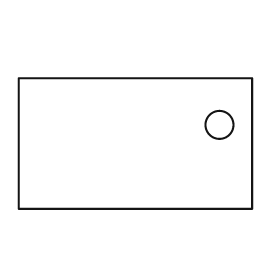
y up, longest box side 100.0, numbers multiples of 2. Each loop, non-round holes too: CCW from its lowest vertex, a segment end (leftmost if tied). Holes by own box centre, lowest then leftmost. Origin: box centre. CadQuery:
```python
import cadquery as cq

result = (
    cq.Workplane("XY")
    .moveTo(-50.0, -28.0)
    .lineTo(50.0, -28.0)
    .lineTo(50.0, 28.0)
    .lineTo(-50.0, 28.0)
    .close()
    .moveTo(36.0, 8.0)
    .circle(6.0)
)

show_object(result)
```